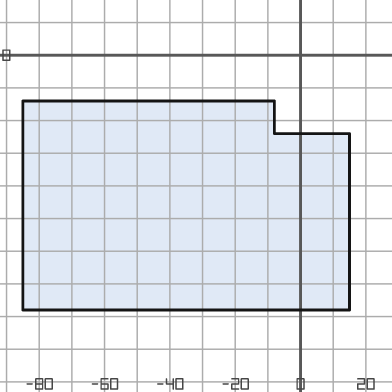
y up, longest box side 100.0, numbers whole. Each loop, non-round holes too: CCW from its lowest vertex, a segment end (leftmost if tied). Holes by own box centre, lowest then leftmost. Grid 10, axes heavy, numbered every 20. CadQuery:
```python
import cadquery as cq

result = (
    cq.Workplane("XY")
    .moveTo(-85.0, -78.0)
    .lineTo(15.0, -78.0)
    .lineTo(15.0, -24.0)
    .lineTo(-8.0, -24.0)
    .lineTo(-8.0, -14.0)
    .lineTo(-85.0, -14.0)
    .close()
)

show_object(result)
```